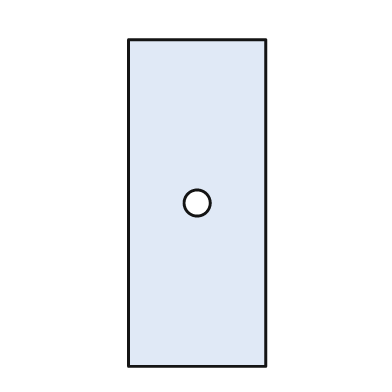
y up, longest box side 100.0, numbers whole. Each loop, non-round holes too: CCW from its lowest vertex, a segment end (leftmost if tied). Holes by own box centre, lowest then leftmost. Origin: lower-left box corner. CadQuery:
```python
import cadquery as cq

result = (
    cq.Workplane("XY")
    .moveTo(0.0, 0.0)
    .lineTo(42.0, 0.0)
    .lineTo(42.0, 100.0)
    .lineTo(0.0, 100.0)
    .close()
    .moveTo(21.0, 50.0)
    .circle(4.0)
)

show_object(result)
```